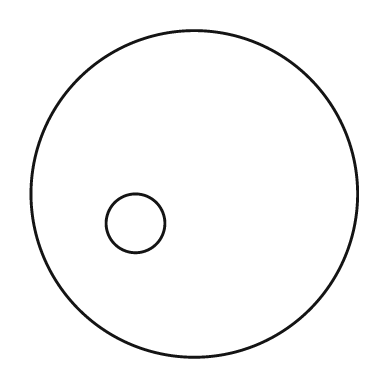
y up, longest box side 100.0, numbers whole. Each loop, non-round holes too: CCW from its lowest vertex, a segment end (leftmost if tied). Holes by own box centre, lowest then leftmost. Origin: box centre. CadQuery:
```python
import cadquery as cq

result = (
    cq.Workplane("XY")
    .moveTo(0.0, 0.0)
    .circle(50.0)
    .moveTo(-18.0, -9.0)
    .circle(9.0)
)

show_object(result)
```